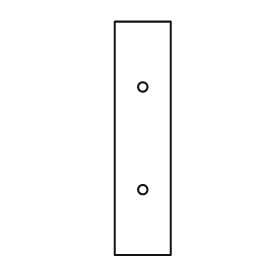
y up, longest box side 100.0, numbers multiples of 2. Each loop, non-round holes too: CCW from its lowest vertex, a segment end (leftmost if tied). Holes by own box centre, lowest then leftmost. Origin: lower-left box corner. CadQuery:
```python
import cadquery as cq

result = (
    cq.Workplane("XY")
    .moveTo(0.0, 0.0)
    .lineTo(24.0, 0.0)
    .lineTo(24.0, 100.0)
    .lineTo(0.0, 100.0)
    .close()
    .moveTo(12.0, 28.0)
    .circle(2.0)
    .moveTo(12.0, 72.0)
    .circle(2.0)
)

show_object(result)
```